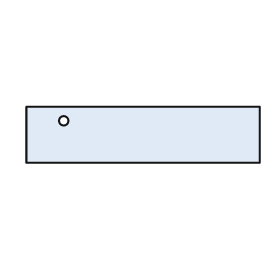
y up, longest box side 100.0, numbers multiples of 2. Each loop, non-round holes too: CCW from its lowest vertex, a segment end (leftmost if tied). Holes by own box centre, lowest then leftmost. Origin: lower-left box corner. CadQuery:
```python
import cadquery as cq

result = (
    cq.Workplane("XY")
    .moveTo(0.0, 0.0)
    .lineTo(100.0, 0.0)
    .lineTo(100.0, 24.0)
    .lineTo(0.0, 24.0)
    .close()
    .moveTo(16.0, 18.0)
    .circle(2.0)
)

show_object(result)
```